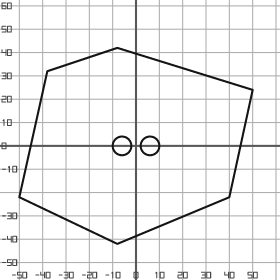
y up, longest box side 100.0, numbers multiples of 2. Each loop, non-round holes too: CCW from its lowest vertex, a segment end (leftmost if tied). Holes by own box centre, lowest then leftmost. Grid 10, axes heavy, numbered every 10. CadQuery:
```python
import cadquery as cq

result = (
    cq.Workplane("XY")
    .moveTo(-8.0, -42.0)
    .lineTo(40.0, -22.0)
    .lineTo(50.0, 24.0)
    .lineTo(-8.0, 42.0)
    .lineTo(-38.0, 32.0)
    .lineTo(-50.0, -22.0)
    .close()
    .moveTo(-6.0, 0.0)
    .circle(4.0)
    .moveTo(6.0, 0.0)
    .circle(4.0)
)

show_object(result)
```